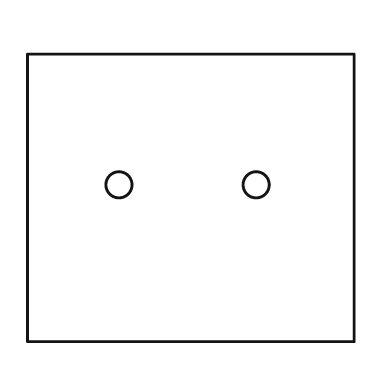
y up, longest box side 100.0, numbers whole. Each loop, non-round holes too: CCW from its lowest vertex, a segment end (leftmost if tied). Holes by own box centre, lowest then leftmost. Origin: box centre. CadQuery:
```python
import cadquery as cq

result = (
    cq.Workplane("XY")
    .moveTo(-50.0, -44.0)
    .lineTo(50.0, -44.0)
    .lineTo(50.0, 44.0)
    .lineTo(-50.0, 44.0)
    .close()
    .moveTo(-22.0, 4.0)
    .circle(4.0)
    .moveTo(20.0, 4.0)
    .circle(4.0)
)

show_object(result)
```